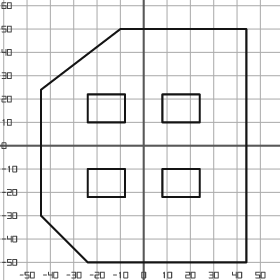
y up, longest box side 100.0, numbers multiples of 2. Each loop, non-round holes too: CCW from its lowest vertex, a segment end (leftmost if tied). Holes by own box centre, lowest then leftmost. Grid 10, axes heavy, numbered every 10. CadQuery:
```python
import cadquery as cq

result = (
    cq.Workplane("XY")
    .moveTo(-24.0, -50.0)
    .lineTo(44.0, -50.0)
    .lineTo(44.0, 50.0)
    .lineTo(-10.0, 50.0)
    .lineTo(-44.0, 24.0)
    .lineTo(-44.0, -30.0)
    .close()
    .moveTo(-24.0, -22.0)
    .lineTo(-8.0, -22.0)
    .lineTo(-8.0, -10.0)
    .lineTo(-24.0, -10.0)
    .close()
    .moveTo(8.0, -22.0)
    .lineTo(24.0, -22.0)
    .lineTo(24.0, -10.0)
    .lineTo(8.0, -10.0)
    .close()
    .moveTo(-24.0, 10.0)
    .lineTo(-8.0, 10.0)
    .lineTo(-8.0, 22.0)
    .lineTo(-24.0, 22.0)
    .close()
    .moveTo(8.0, 10.0)
    .lineTo(24.0, 10.0)
    .lineTo(24.0, 22.0)
    .lineTo(8.0, 22.0)
    .close()
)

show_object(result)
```